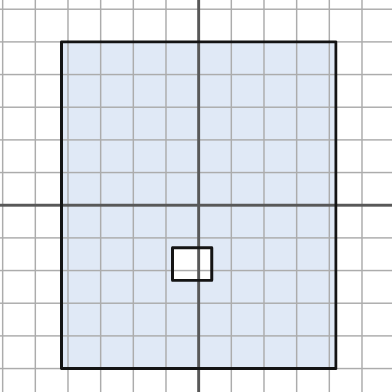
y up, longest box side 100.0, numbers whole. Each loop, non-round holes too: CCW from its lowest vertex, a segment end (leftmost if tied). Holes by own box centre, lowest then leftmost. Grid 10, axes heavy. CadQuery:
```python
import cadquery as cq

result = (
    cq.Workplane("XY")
    .moveTo(-42.0, -50.0)
    .lineTo(42.0, -50.0)
    .lineTo(42.0, 50.0)
    .lineTo(-42.0, 50.0)
    .close()
    .moveTo(-8.0, -23.0)
    .lineTo(4.0, -23.0)
    .lineTo(4.0, -13.0)
    .lineTo(-8.0, -13.0)
    .close()
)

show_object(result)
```